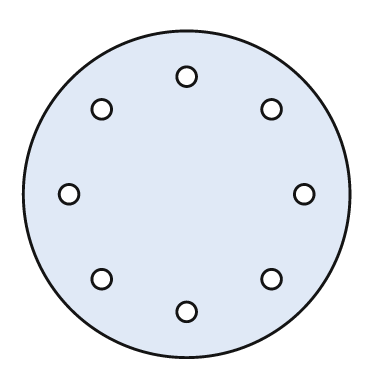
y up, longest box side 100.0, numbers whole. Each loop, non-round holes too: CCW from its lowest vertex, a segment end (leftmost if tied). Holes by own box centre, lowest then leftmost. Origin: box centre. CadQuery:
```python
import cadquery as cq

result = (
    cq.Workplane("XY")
    .moveTo(0.0, 0.0)
    .circle(50.0)
    .moveTo(0.0, -36.0)
    .circle(3.0)
    .moveTo(-26.0, -26.0)
    .circle(3.0)
    .moveTo(26.0, -26.0)
    .circle(3.0)
    .moveTo(-36.0, 0.0)
    .circle(3.0)
    .moveTo(36.0, 0.0)
    .circle(3.0)
    .moveTo(-26.0, 26.0)
    .circle(3.0)
    .moveTo(26.0, 26.0)
    .circle(3.0)
    .moveTo(0.0, 36.0)
    .circle(3.0)
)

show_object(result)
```